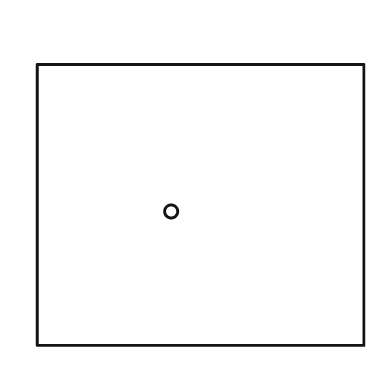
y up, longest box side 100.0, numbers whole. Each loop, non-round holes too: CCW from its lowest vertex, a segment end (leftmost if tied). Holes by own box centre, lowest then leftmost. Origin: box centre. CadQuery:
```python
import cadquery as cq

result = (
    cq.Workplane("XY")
    .moveTo(-50.0, -43.0)
    .lineTo(50.0, -43.0)
    .lineTo(50.0, 43.0)
    .lineTo(-50.0, 43.0)
    .close()
    .moveTo(-9.0, -2.0)
    .circle(2.0)
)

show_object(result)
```